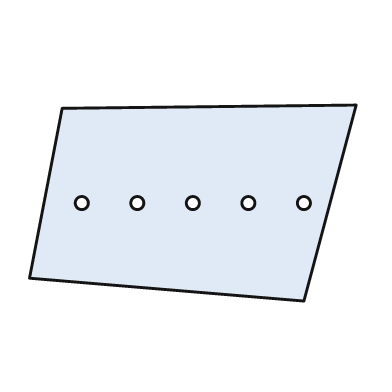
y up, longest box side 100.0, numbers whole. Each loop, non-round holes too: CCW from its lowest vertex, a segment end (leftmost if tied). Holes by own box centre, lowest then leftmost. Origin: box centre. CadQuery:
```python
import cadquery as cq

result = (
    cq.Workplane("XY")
    .moveTo(34.0, -30.0)
    .lineTo(50.0, 30.0)
    .lineTo(-40.0, 29.0)
    .lineTo(-50.0, -23.0)
    .close()
    .moveTo(-34.0, 0.0)
    .circle(2.0)
    .moveTo(-17.0, 0.0)
    .circle(2.0)
    .moveTo(0.0, 0.0)
    .circle(2.0)
    .moveTo(17.0, 0.0)
    .circle(2.0)
    .moveTo(34.0, 0.0)
    .circle(2.0)
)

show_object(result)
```